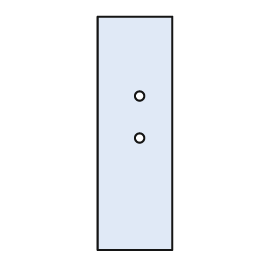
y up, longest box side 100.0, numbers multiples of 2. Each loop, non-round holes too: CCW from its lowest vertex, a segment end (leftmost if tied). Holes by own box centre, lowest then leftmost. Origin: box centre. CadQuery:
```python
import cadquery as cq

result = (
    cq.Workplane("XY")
    .moveTo(-16.0, -50.0)
    .lineTo(16.0, -50.0)
    .lineTo(16.0, 50.0)
    .lineTo(-16.0, 50.0)
    .close()
    .moveTo(2.0, -2.0)
    .circle(2.0)
    .moveTo(2.0, 16.0)
    .circle(2.0)
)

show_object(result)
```